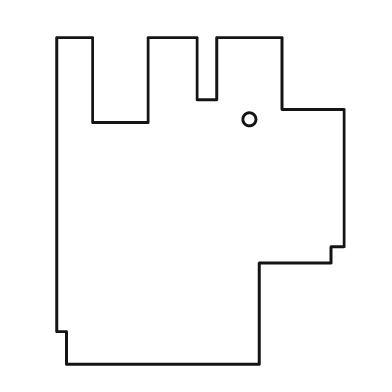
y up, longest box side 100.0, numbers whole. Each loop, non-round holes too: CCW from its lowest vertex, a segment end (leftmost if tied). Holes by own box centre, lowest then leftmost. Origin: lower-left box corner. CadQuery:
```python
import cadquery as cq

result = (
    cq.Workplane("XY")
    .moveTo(3.0, 0.0)
    .lineTo(62.0, 0.0)
    .lineTo(62.0, 31.0)
    .lineTo(84.0, 31.0)
    .lineTo(84.0, 36.0)
    .lineTo(88.0, 36.0)
    .lineTo(88.0, 78.0)
    .lineTo(69.0, 78.0)
    .lineTo(69.0, 100.0)
    .lineTo(49.0, 100.0)
    .lineTo(49.0, 81.0)
    .lineTo(43.0, 81.0)
    .lineTo(43.0, 100.0)
    .lineTo(28.0, 100.0)
    .lineTo(28.0, 74.0)
    .lineTo(11.0, 74.0)
    .lineTo(11.0, 100.0)
    .lineTo(0.0, 100.0)
    .lineTo(0.0, 10.0)
    .lineTo(3.0, 10.0)
    .close()
    .moveTo(59.0, 75.0)
    .circle(2.0)
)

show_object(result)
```